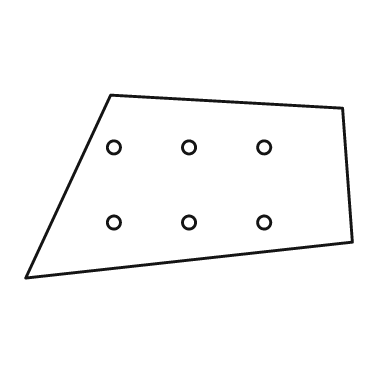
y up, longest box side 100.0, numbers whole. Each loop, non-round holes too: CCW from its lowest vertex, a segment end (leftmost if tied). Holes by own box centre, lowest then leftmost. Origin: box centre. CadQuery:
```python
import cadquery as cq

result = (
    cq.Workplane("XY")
    .moveTo(-50.0, -28.0)
    .lineTo(50.0, -17.0)
    .lineTo(47.0, 24.0)
    .lineTo(-24.0, 28.0)
    .close()
    .moveTo(-23.0, -11.0)
    .circle(2.0)
    .moveTo(0.0, -11.0)
    .circle(2.0)
    .moveTo(23.0, -11.0)
    .circle(2.0)
    .moveTo(-23.0, 12.0)
    .circle(2.0)
    .moveTo(0.0, 12.0)
    .circle(2.0)
    .moveTo(23.0, 12.0)
    .circle(2.0)
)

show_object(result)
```